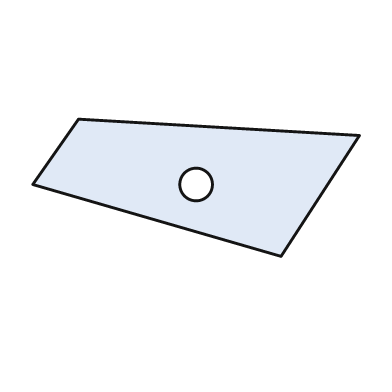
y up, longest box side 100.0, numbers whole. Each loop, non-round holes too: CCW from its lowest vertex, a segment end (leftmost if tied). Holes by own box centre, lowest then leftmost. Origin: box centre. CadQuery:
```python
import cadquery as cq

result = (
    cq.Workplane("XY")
    .moveTo(26.0, -21.0)
    .lineTo(50.0, 16.0)
    .lineTo(-36.0, 21.0)
    .lineTo(-50.0, 1.0)
    .close()
    .moveTo(0.0, 1.0)
    .circle(5.0)
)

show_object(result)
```